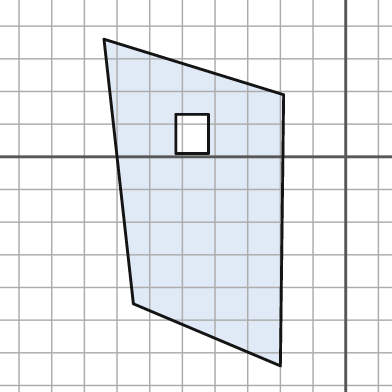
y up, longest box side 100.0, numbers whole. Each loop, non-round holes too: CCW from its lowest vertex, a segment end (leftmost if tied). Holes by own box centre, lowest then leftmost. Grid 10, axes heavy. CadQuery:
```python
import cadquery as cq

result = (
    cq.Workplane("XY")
    .moveTo(-20.0, -64.0)
    .lineTo(-19.0, 19.0)
    .lineTo(-74.0, 36.0)
    .lineTo(-65.0, -45.0)
    .close()
    .moveTo(-52.0, 1.0)
    .lineTo(-42.0, 1.0)
    .lineTo(-42.0, 13.0)
    .lineTo(-52.0, 13.0)
    .close()
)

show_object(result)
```